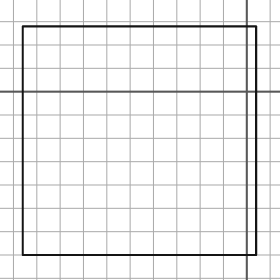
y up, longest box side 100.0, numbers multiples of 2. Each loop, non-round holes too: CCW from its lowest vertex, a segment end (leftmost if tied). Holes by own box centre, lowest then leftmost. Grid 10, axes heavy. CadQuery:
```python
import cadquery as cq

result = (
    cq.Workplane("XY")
    .moveTo(-96.0, -70.0)
    .lineTo(4.0, -70.0)
    .lineTo(4.0, 28.0)
    .lineTo(-96.0, 28.0)
    .close()
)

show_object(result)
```